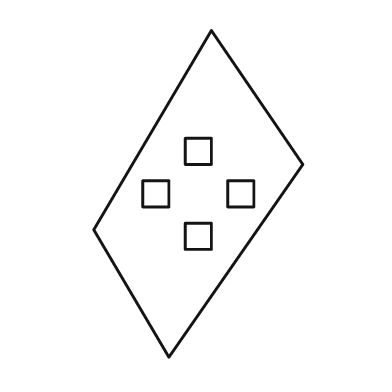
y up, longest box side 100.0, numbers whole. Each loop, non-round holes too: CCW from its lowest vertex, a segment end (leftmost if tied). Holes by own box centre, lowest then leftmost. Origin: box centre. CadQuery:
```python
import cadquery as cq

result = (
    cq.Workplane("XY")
    .moveTo(-9.0, -50.0)
    .lineTo(32.0, 9.0)
    .lineTo(4.0, 50.0)
    .lineTo(-32.0, -11.0)
    .close()
    .moveTo(-4.0, -17.0)
    .lineTo(4.0, -17.0)
    .lineTo(4.0, -9.0)
    .lineTo(-4.0, -9.0)
    .close()
    .moveTo(-17.0, -4.0)
    .lineTo(-9.0, -4.0)
    .lineTo(-9.0, 4.0)
    .lineTo(-17.0, 4.0)
    .close()
    .moveTo(9.0, -4.0)
    .lineTo(17.0, -4.0)
    .lineTo(17.0, 4.0)
    .lineTo(9.0, 4.0)
    .close()
    .moveTo(-4.0, 9.0)
    .lineTo(4.0, 9.0)
    .lineTo(4.0, 17.0)
    .lineTo(-4.0, 17.0)
    .close()
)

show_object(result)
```